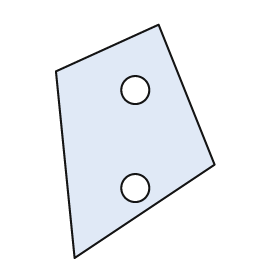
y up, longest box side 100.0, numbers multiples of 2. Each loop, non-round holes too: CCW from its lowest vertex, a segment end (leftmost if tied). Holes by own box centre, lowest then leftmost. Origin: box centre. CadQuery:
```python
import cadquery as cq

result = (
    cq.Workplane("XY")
    .moveTo(-26.0, -50.0)
    .lineTo(34.0, -10.0)
    .lineTo(10.0, 50.0)
    .lineTo(-34.0, 30.0)
    .close()
    .moveTo(0.0, -20.0)
    .circle(6.0)
    .moveTo(0.0, 22.0)
    .circle(6.0)
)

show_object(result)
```